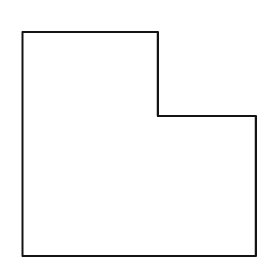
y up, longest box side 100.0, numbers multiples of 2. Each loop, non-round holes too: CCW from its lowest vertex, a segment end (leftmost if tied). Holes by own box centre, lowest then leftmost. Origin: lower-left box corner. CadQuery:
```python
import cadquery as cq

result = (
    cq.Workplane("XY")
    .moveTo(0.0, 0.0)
    .lineTo(100.0, 0.0)
    .lineTo(100.0, 60.0)
    .lineTo(58.0, 60.0)
    .lineTo(58.0, 96.0)
    .lineTo(0.0, 96.0)
    .close()
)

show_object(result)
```